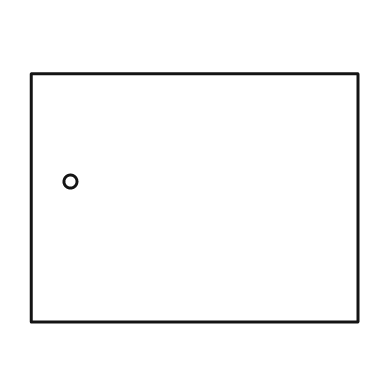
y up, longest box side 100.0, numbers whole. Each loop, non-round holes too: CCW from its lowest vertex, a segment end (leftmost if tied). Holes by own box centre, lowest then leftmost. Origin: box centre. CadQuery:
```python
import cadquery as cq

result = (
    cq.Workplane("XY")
    .moveTo(-50.0, -38.0)
    .lineTo(50.0, -38.0)
    .lineTo(50.0, 38.0)
    .lineTo(-50.0, 38.0)
    .close()
    .moveTo(-38.0, 5.0)
    .circle(2.0)
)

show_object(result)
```